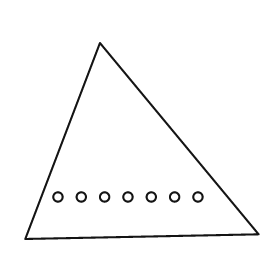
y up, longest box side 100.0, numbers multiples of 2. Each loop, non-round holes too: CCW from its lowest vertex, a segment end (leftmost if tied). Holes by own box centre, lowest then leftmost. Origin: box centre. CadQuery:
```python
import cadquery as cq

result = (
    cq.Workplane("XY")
    .moveTo(-50.0, -42.0)
    .lineTo(50.0, -40.0)
    .lineTo(-18.0, 42.0)
    .close()
    .moveTo(-36.0, -24.0)
    .circle(2.0)
    .moveTo(-26.0, -24.0)
    .circle(2.0)
    .moveTo(-16.0, -24.0)
    .circle(2.0)
    .moveTo(-6.0, -24.0)
    .circle(2.0)
    .moveTo(4.0, -24.0)
    .circle(2.0)
    .moveTo(14.0, -24.0)
    .circle(2.0)
    .moveTo(24.0, -24.0)
    .circle(2.0)
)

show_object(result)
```